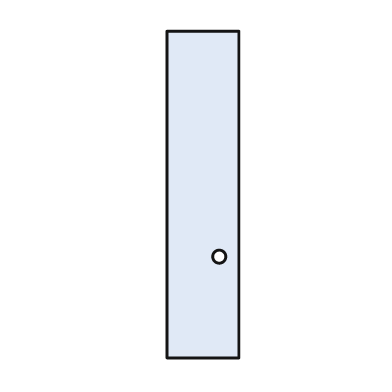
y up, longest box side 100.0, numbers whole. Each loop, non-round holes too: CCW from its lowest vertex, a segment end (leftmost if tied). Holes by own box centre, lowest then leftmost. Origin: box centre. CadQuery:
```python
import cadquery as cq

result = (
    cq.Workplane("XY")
    .moveTo(-11.0, -50.0)
    .lineTo(11.0, -50.0)
    .lineTo(11.0, 50.0)
    .lineTo(-11.0, 50.0)
    .close()
    .moveTo(5.0, -19.0)
    .circle(2.0)
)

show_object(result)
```